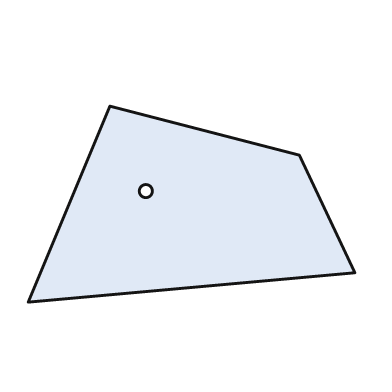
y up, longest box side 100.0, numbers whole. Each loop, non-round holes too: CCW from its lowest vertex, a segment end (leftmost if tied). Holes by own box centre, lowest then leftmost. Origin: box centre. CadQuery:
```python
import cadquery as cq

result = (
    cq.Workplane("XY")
    .moveTo(-50.0, -30.0)
    .lineTo(50.0, -21.0)
    .lineTo(33.0, 15.0)
    .lineTo(-25.0, 30.0)
    .close()
    .moveTo(-14.0, 4.0)
    .circle(2.0)
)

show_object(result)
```